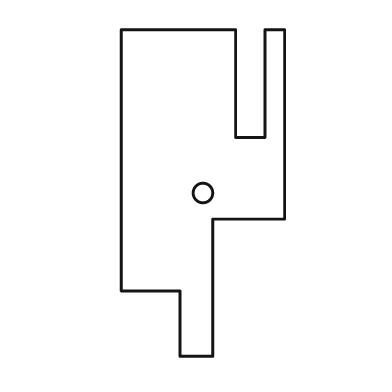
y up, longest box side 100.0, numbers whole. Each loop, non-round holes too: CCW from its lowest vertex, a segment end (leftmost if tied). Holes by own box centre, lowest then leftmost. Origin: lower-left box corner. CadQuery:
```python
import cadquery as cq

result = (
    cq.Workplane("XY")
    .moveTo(18.0, 0.0)
    .lineTo(28.0, 0.0)
    .lineTo(28.0, 42.0)
    .lineTo(50.0, 42.0)
    .lineTo(50.0, 100.0)
    .lineTo(44.0, 100.0)
    .lineTo(44.0, 67.0)
    .lineTo(35.0, 67.0)
    .lineTo(35.0, 100.0)
    .lineTo(0.0, 100.0)
    .lineTo(0.0, 20.0)
    .lineTo(18.0, 20.0)
    .close()
    .moveTo(25.0, 50.0)
    .circle(3.0)
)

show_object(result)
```